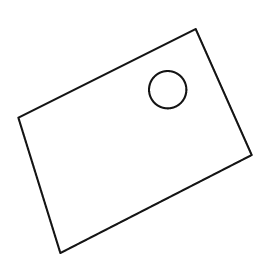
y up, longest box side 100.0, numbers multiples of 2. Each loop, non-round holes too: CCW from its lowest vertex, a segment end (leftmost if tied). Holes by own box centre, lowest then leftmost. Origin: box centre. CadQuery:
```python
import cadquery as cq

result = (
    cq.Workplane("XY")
    .moveTo(-32.0, -48.0)
    .lineTo(50.0, -6.0)
    .lineTo(26.0, 48.0)
    .lineTo(-50.0, 10.0)
    .close()
    .moveTo(14.0, 22.0)
    .circle(8.0)
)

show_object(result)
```